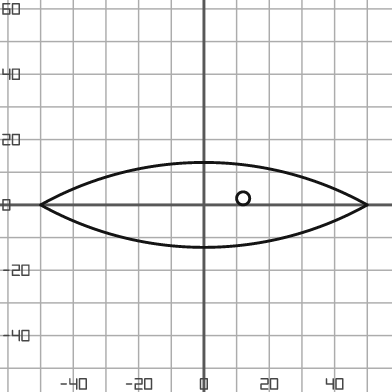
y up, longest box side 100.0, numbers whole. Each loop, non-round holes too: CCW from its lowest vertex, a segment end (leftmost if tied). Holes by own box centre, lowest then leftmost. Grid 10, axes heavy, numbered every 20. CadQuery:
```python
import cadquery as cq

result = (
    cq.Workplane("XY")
    .moveTo(-50.0, 0.0)
    .threePointArc((0.0, -13.0), (50.0, 0.0))
    .threePointArc((0.0, 13.0), (-50.0, 0.0))
    .close()
    .moveTo(12.0, 2.0)
    .circle(2.0)
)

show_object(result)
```